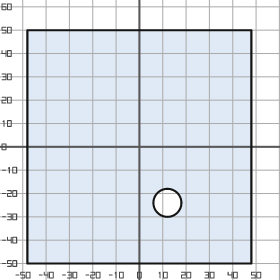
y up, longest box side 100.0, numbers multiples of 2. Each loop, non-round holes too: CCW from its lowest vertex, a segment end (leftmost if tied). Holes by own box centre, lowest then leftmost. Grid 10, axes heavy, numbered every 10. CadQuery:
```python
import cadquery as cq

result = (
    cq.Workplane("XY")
    .moveTo(-48.0, -50.0)
    .lineTo(48.0, -50.0)
    .lineTo(48.0, 50.0)
    .lineTo(-48.0, 50.0)
    .close()
    .moveTo(12.0, -24.0)
    .circle(6.0)
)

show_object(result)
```